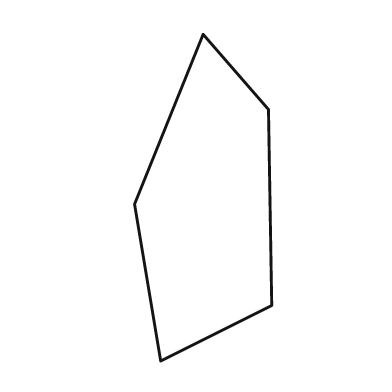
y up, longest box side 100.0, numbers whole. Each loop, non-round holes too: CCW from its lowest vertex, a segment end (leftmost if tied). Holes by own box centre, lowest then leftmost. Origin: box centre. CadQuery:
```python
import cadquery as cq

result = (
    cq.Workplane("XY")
    .moveTo(-13.0, -50.0)
    .lineTo(21.0, -33.0)
    .lineTo(20.0, 27.0)
    .lineTo(0.0, 50.0)
    .lineTo(-21.0, -2.0)
    .close()
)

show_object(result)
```